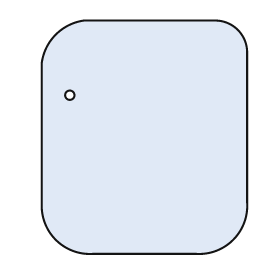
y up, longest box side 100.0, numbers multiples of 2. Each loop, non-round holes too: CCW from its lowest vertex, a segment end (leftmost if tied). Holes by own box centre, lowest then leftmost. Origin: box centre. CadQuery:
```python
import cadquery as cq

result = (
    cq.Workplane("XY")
    .moveTo(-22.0, -50.0)
    .lineTo(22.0, -50.0)
    .threePointArc((38.0, -44.0), (44.0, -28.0))
    .lineTo(44.0, 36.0)
    .threePointArc((40.0, 46.0), (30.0, 50.0))
    .lineTo(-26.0, 50.0)
    .threePointArc((-38.0, 44.0), (-44.0, 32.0))
    .lineTo(-44.0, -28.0)
    .threePointArc((-38.0, -44.0), (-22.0, -50.0))
    .close()
    .moveTo(-32.0, 18.0)
    .circle(2.0)
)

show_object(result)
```